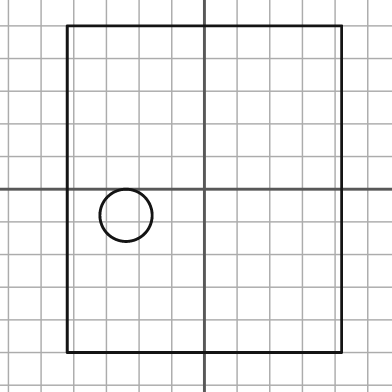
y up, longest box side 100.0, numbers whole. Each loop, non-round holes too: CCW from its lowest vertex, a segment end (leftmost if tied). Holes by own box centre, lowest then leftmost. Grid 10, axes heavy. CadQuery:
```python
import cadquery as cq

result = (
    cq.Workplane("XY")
    .moveTo(-42.0, -50.0)
    .lineTo(42.0, -50.0)
    .lineTo(42.0, 50.0)
    .lineTo(-42.0, 50.0)
    .close()
    .moveTo(-24.0, -8.0)
    .circle(8.0)
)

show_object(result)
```